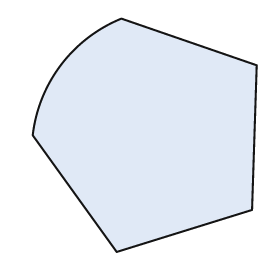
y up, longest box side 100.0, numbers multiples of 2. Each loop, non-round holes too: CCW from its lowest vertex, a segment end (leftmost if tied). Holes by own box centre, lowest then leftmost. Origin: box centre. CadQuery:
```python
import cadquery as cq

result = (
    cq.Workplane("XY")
    .moveTo(-12.0, -50.0)
    .lineTo(46.0, -32.0)
    .lineTo(48.0, 30.0)
    .lineTo(-10.0, 50.0)
    .threePointArc((-36.0, 30.0), (-48.0, 0.0))
    .close()
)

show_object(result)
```